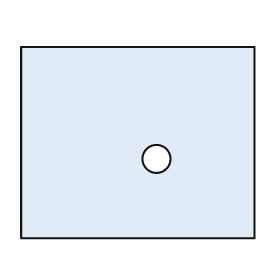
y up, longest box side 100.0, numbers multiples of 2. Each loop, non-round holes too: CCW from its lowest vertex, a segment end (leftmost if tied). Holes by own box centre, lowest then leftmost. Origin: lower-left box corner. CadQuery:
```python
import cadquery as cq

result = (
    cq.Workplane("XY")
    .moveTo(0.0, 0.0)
    .lineTo(100.0, 0.0)
    .lineTo(100.0, 82.0)
    .lineTo(0.0, 82.0)
    .close()
    .moveTo(58.0, 34.0)
    .circle(6.0)
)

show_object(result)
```